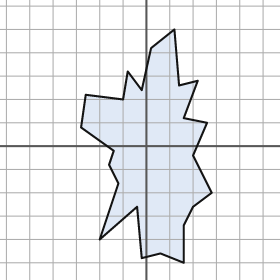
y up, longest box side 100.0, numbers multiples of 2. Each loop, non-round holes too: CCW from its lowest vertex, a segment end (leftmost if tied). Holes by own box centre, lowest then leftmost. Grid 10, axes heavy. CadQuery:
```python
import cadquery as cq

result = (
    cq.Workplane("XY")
    .moveTo(16.0, -50.0)
    .lineTo(16.0, -34.0)
    .lineTo(20.0, -26.0)
    .lineTo(28.0, -20.0)
    .lineTo(20.0, -4.0)
    .lineTo(26.0, 10.0)
    .lineTo(16.0, 12.0)
    .lineTo(22.0, 28.0)
    .lineTo(14.0, 26.0)
    .lineTo(12.0, 50.0)
    .lineTo(2.0, 42.0)
    .lineTo(-2.0, 24.0)
    .lineTo(-8.0, 32.0)
    .lineTo(-10.0, 20.0)
    .lineTo(-26.0, 22.0)
    .lineTo(-28.0, 8.0)
    .lineTo(-14.0, -2.0)
    .lineTo(-16.0, -8.0)
    .lineTo(-12.0, -16.0)
    .lineTo(-20.0, -40.0)
    .lineTo(-4.0, -26.0)
    .lineTo(-2.0, -48.0)
    .lineTo(6.0, -46.0)
    .close()
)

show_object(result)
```